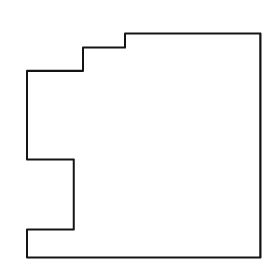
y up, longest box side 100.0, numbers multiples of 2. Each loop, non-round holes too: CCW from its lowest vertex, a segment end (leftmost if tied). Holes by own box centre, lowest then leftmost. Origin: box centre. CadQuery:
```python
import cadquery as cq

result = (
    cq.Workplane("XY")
    .moveTo(-50.0, -48.0)
    .lineTo(50.0, -48.0)
    .lineTo(50.0, 48.0)
    .lineTo(-8.0, 48.0)
    .lineTo(-8.0, 42.0)
    .lineTo(-26.0, 42.0)
    .lineTo(-26.0, 32.0)
    .lineTo(-50.0, 32.0)
    .lineTo(-50.0, -6.0)
    .lineTo(-30.0, -6.0)
    .lineTo(-30.0, -36.0)
    .lineTo(-50.0, -36.0)
    .close()
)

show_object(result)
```